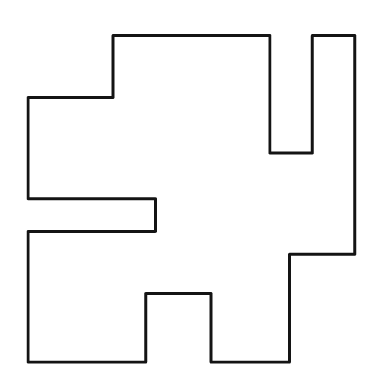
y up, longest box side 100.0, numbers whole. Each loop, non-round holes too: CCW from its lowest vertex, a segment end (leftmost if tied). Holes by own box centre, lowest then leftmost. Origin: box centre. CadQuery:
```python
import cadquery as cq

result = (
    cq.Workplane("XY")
    .moveTo(-50.0, -50.0)
    .lineTo(-14.0, -50.0)
    .lineTo(-14.0, -29.0)
    .lineTo(6.0, -29.0)
    .lineTo(6.0, -50.0)
    .lineTo(30.0, -50.0)
    .lineTo(30.0, -17.0)
    .lineTo(50.0, -17.0)
    .lineTo(50.0, 50.0)
    .lineTo(37.0, 50.0)
    .lineTo(37.0, 14.0)
    .lineTo(24.0, 14.0)
    .lineTo(24.0, 50.0)
    .lineTo(-24.0, 50.0)
    .lineTo(-24.0, 31.0)
    .lineTo(-50.0, 31.0)
    .lineTo(-50.0, 0.0)
    .lineTo(-11.0, 0.0)
    .lineTo(-11.0, -10.0)
    .lineTo(-50.0, -10.0)
    .close()
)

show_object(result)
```